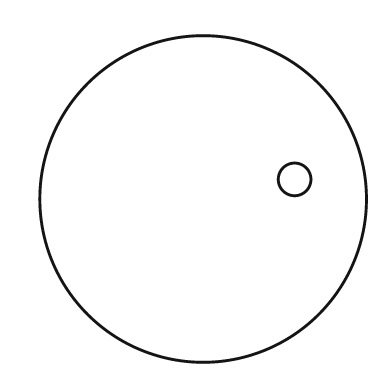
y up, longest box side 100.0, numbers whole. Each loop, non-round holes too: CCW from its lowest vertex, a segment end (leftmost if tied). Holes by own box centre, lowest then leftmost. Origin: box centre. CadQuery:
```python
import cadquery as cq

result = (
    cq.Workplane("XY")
    .moveTo(0.0, 0.0)
    .circle(50.0)
    .moveTo(28.0, 6.0)
    .circle(5.0)
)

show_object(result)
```